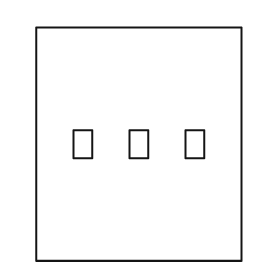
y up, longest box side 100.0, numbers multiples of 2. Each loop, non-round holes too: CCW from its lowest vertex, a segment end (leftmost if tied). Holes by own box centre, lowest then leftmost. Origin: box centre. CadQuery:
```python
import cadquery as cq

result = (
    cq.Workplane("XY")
    .moveTo(-44.0, -50.0)
    .lineTo(44.0, -50.0)
    .lineTo(44.0, 50.0)
    .lineTo(-44.0, 50.0)
    .close()
    .moveTo(-28.0, -6.0)
    .lineTo(-20.0, -6.0)
    .lineTo(-20.0, 6.0)
    .lineTo(-28.0, 6.0)
    .close()
    .moveTo(-4.0, -6.0)
    .lineTo(4.0, -6.0)
    .lineTo(4.0, 6.0)
    .lineTo(-4.0, 6.0)
    .close()
    .moveTo(20.0, -6.0)
    .lineTo(28.0, -6.0)
    .lineTo(28.0, 6.0)
    .lineTo(20.0, 6.0)
    .close()
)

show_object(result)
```